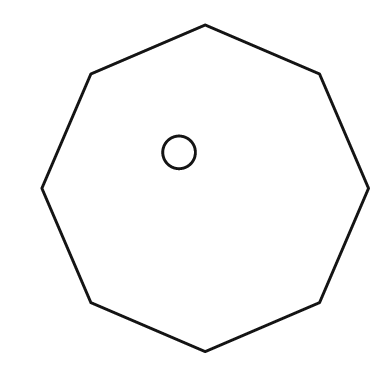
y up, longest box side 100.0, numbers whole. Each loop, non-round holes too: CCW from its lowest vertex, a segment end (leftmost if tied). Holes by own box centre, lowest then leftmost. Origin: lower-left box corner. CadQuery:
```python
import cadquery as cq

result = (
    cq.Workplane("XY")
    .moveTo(50.0, 0.0)
    .lineTo(85.0, 15.0)
    .lineTo(100.0, 50.0)
    .lineTo(85.0, 85.0)
    .lineTo(50.0, 100.0)
    .lineTo(15.0, 85.0)
    .lineTo(0.0, 50.0)
    .lineTo(15.0, 15.0)
    .close()
    .moveTo(42.0, 61.0)
    .circle(5.0)
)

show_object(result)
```